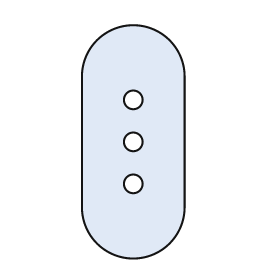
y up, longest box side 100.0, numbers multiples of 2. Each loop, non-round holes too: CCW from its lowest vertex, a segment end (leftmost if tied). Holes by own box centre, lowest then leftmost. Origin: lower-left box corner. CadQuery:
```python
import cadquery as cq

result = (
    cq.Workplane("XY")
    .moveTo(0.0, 22.0)
    .threePointArc((22.0, 0.0), (44.0, 22.0))
    .lineTo(44.0, 78.0)
    .threePointArc((22.0, 100.0), (0.0, 78.0))
    .close()
    .moveTo(22.0, 32.0)
    .circle(4.0)
    .moveTo(22.0, 50.0)
    .circle(4.0)
    .moveTo(22.0, 68.0)
    .circle(4.0)
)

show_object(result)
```